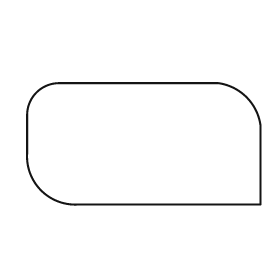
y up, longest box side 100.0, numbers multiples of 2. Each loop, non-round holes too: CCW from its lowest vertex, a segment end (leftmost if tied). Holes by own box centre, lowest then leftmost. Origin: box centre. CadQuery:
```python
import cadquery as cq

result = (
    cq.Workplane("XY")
    .moveTo(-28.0, -26.0)
    .lineTo(50.0, -26.0)
    .lineTo(50.0, 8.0)
    .threePointArc((44.0, 20.0), (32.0, 26.0))
    .lineTo(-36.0, 26.0)
    .threePointArc((-46.0, 22.0), (-50.0, 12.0))
    .lineTo(-50.0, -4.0)
    .threePointArc((-44.0, -20.0), (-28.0, -26.0))
    .close()
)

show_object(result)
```